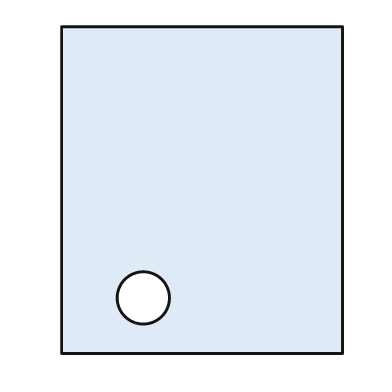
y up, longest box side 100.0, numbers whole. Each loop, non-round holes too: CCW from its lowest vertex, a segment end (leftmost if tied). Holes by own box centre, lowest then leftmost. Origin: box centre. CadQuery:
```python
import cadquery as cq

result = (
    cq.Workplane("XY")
    .moveTo(-43.0, -50.0)
    .lineTo(43.0, -50.0)
    .lineTo(43.0, 50.0)
    .lineTo(-43.0, 50.0)
    .close()
    .moveTo(-18.0, -33.0)
    .circle(8.0)
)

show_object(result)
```